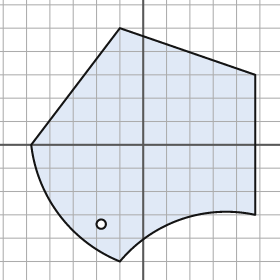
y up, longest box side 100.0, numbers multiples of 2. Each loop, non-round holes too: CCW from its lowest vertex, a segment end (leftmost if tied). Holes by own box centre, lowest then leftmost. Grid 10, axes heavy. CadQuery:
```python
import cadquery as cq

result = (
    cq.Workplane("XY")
    .moveTo(-10.0, -50.0)
    .threePointArc((16.0, -32.0), (48.0, -30.0))
    .lineTo(48.0, 30.0)
    .lineTo(-10.0, 50.0)
    .lineTo(-48.0, 0.0)
    .threePointArc((-36.0, -30.0), (-10.0, -50.0))
    .close()
    .moveTo(-18.0, -34.0)
    .circle(2.0)
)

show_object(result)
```